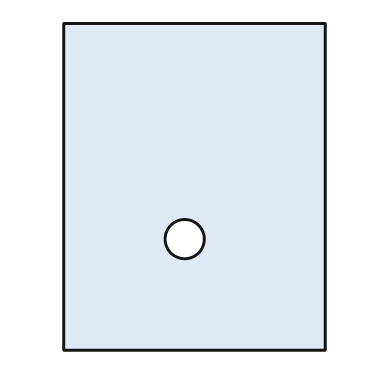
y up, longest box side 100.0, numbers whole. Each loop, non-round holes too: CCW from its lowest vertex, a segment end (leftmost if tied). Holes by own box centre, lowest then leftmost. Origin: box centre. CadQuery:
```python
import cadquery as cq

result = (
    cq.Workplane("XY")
    .moveTo(-40.0, -50.0)
    .lineTo(40.0, -50.0)
    .lineTo(40.0, 50.0)
    .lineTo(-40.0, 50.0)
    .close()
    .moveTo(-3.0, -16.0)
    .circle(6.0)
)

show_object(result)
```